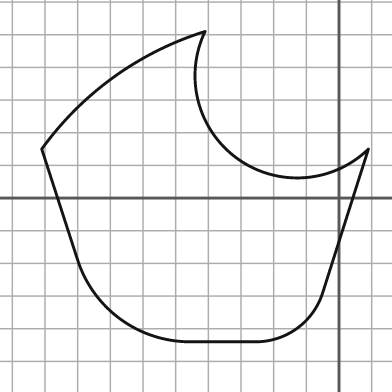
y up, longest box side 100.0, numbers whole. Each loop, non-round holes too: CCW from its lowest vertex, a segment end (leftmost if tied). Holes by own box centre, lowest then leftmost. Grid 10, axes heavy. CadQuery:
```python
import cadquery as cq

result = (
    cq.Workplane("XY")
    .moveTo(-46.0, -44.0)
    .lineTo(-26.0, -44.0)
    .threePointArc((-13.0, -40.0), (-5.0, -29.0))
    .lineTo(9.0, 15.0)
    .threePointArc((-31.0, 12.0), (-41.0, 51.0))
    .threePointArc((-69.0, 37.0), (-91.0, 15.0))
    .lineTo(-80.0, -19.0)
    .threePointArc((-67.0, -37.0), (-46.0, -44.0))
    .close()
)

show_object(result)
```